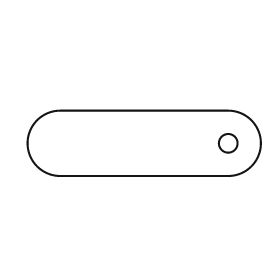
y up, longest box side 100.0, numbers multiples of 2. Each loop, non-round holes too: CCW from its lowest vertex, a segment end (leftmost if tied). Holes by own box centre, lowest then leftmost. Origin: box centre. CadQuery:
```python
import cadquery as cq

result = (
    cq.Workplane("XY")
    .moveTo(-36.0, -14.0)
    .lineTo(36.0, -14.0)
    .threePointArc((50.0, 0.0), (36.0, 14.0))
    .lineTo(-36.0, 14.0)
    .threePointArc((-50.0, 0.0), (-36.0, -14.0))
    .close()
    .moveTo(36.0, 0.0)
    .circle(4.0)
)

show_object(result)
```